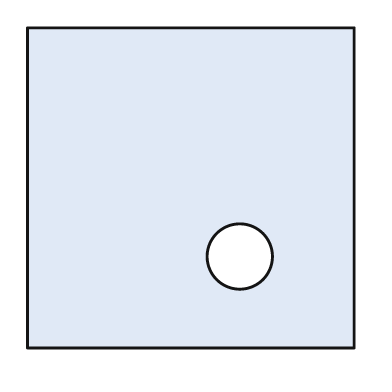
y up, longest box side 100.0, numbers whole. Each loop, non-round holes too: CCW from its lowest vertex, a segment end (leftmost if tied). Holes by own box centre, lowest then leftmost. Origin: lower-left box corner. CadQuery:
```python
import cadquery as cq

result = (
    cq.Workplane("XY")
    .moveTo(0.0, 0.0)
    .lineTo(100.0, 0.0)
    .lineTo(100.0, 98.0)
    .lineTo(0.0, 98.0)
    .close()
    .moveTo(65.0, 28.0)
    .circle(10.0)
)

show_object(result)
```